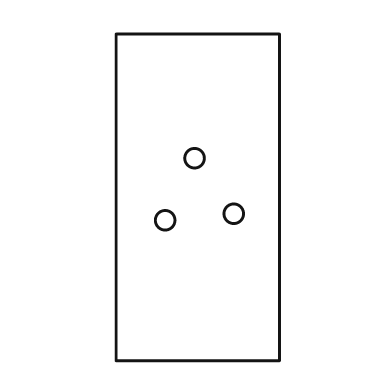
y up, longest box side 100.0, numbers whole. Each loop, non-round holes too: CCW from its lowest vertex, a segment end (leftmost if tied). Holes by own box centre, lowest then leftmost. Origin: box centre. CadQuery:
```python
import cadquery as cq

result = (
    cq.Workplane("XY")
    .moveTo(-25.0, -50.0)
    .lineTo(25.0, -50.0)
    .lineTo(25.0, 50.0)
    .lineTo(-25.0, 50.0)
    .close()
    .moveTo(-10.0, -7.0)
    .circle(3.0)
    .moveTo(11.0, -5.0)
    .circle(3.0)
    .moveTo(-1.0, 12.0)
    .circle(3.0)
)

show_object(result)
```